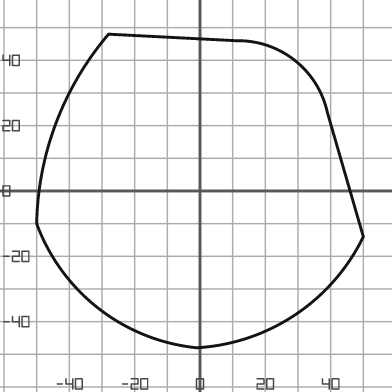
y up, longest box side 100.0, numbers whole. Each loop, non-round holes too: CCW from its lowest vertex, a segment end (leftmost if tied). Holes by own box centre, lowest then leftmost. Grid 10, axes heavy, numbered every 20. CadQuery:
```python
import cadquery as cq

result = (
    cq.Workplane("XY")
    .moveTo(-1.0, -48.0)
    .threePointArc((29.0, -38.0), (50.0, -14.0))
    .lineTo(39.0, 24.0)
    .threePointArc((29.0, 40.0), (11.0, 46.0))
    .lineTo(-28.0, 48.0)
    .threePointArc((-44.0, 21.0), (-50.0, -10.0))
    .threePointArc((-31.0, -36.0), (-1.0, -48.0))
    .close()
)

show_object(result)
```